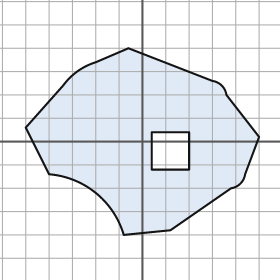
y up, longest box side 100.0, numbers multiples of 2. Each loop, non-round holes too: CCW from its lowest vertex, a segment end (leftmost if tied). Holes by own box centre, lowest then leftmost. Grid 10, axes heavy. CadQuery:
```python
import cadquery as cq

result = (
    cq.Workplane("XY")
    .moveTo(-8.0, -40.0)
    .lineTo(12.0, -38.0)
    .lineTo(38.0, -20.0)
    .threePointArc((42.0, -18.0), (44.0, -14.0))
    .lineTo(50.0, 2.0)
    .lineTo(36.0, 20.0)
    .threePointArc((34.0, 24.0), (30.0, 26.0))
    .lineTo(-6.0, 40.0)
    .lineTo(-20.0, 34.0)
    .threePointArc((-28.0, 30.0), (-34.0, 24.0))
    .lineTo(-50.0, 6.0)
    .lineTo(-40.0, -14.0)
    .threePointArc((-20.0, -22.0), (-8.0, -40.0))
    .close()
    .moveTo(4.0, -12.0)
    .lineTo(20.0, -12.0)
    .lineTo(20.0, 4.0)
    .lineTo(4.0, 4.0)
    .close()
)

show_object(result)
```